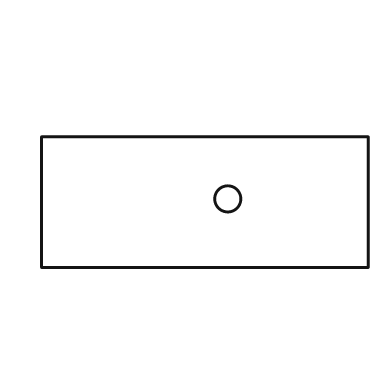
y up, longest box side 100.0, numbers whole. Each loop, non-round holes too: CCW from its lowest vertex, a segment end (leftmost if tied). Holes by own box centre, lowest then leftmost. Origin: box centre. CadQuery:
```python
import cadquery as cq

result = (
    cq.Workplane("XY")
    .moveTo(-50.0, -20.0)
    .lineTo(50.0, -20.0)
    .lineTo(50.0, 20.0)
    .lineTo(-50.0, 20.0)
    .close()
    .moveTo(7.0, 1.0)
    .circle(4.0)
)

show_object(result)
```